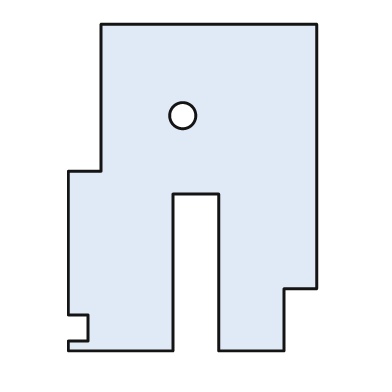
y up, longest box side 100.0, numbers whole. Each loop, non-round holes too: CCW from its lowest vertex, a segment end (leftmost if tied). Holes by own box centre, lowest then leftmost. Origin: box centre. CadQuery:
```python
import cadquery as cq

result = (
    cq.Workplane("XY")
    .moveTo(-38.0, -50.0)
    .lineTo(-6.0, -50.0)
    .lineTo(-6.0, -2.0)
    .lineTo(8.0, -2.0)
    .lineTo(8.0, -50.0)
    .lineTo(28.0, -50.0)
    .lineTo(28.0, -31.0)
    .lineTo(38.0, -31.0)
    .lineTo(38.0, 50.0)
    .lineTo(-28.0, 50.0)
    .lineTo(-28.0, 5.0)
    .lineTo(-38.0, 5.0)
    .lineTo(-38.0, -39.0)
    .lineTo(-32.0, -39.0)
    .lineTo(-32.0, -47.0)
    .lineTo(-38.0, -47.0)
    .close()
    .moveTo(-3.0, 22.0)
    .circle(4.0)
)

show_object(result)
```